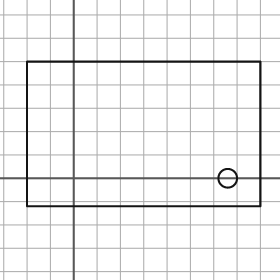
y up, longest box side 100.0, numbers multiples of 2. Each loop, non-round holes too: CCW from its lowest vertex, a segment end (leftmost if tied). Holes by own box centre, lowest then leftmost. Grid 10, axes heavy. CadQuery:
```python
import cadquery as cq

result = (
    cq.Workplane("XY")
    .moveTo(-20.0, -12.0)
    .lineTo(80.0, -12.0)
    .lineTo(80.0, 50.0)
    .lineTo(-20.0, 50.0)
    .close()
    .moveTo(66.0, 0.0)
    .circle(4.0)
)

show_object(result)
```